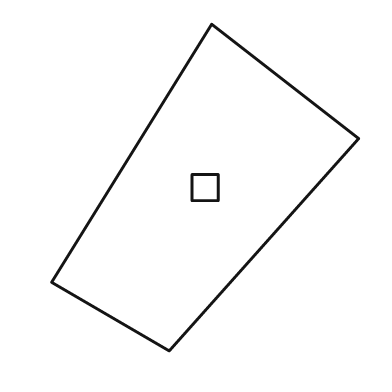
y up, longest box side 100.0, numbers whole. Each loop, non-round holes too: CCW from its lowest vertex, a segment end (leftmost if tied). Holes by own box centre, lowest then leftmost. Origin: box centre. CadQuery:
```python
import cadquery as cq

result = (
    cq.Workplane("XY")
    .moveTo(-11.0, -50.0)
    .lineTo(47.0, 15.0)
    .lineTo(2.0, 50.0)
    .lineTo(-47.0, -29.0)
    .close()
    .moveTo(-4.0, -4.0)
    .lineTo(4.0, -4.0)
    .lineTo(4.0, 4.0)
    .lineTo(-4.0, 4.0)
    .close()
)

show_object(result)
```